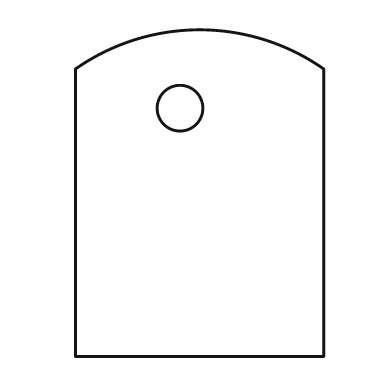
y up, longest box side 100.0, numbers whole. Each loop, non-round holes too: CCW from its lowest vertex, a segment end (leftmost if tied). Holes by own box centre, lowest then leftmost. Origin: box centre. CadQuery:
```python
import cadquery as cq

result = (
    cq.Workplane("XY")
    .moveTo(-38.0, -50.0)
    .lineTo(38.0, -50.0)
    .lineTo(38.0, 38.0)
    .threePointArc((0.0, 50.0), (-38.0, 38.0))
    .close()
    .moveTo(-6.0, 26.0)
    .circle(7.0)
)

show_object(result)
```